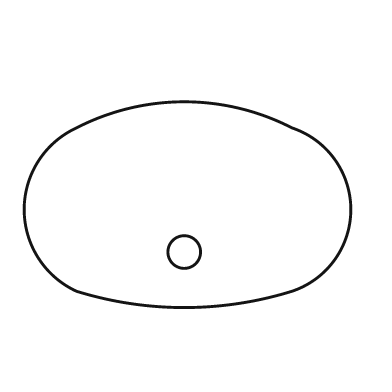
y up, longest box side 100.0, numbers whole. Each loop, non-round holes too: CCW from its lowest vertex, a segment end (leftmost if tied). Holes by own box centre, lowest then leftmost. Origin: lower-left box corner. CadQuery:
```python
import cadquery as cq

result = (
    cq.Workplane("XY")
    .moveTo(16.0, 5.0)
    .threePointArc((49.0, 0.0), (82.0, 5.0))
    .threePointArc((100.0, 30.0), (82.0, 55.0))
    .threePointArc((49.0, 63.0), (16.0, 55.0))
    .threePointArc((0.0, 30.0), (16.0, 5.0))
    .close()
    .moveTo(49.0, 17.0)
    .circle(5.0)
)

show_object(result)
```